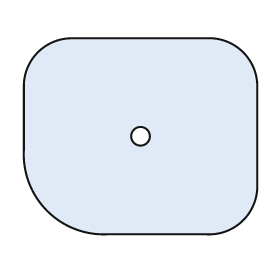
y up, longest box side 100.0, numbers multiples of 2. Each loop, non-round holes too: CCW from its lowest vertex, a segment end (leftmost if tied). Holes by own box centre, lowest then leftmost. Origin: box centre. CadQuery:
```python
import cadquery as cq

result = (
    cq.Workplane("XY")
    .moveTo(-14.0, -42.0)
    .lineTo(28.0, -42.0)
    .threePointArc((44.0, -36.0), (50.0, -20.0))
    .lineTo(50.0, 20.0)
    .threePointArc((44.0, 36.0), (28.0, 42.0))
    .lineTo(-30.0, 42.0)
    .threePointArc((-44.0, 36.0), (-50.0, 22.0))
    .lineTo(-50.0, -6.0)
    .threePointArc((-40.0, -32.0), (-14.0, -42.0))
    .close()
    .moveTo(0.0, 0.0)
    .circle(4.0)
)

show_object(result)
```